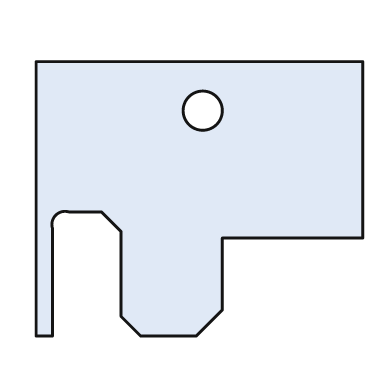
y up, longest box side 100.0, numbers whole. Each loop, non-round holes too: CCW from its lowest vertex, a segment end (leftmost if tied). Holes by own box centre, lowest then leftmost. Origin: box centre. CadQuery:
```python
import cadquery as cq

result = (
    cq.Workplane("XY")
    .moveTo(-50.0, -42.0)
    .lineTo(-45.0, -42.0)
    .lineTo(-45.0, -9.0)
    .threePointArc((-44.0, -5.0), (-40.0, -4.0))
    .lineTo(-30.0, -4.0)
    .lineTo(-24.0, -10.0)
    .lineTo(-24.0, -36.0)
    .lineTo(-18.0, -42.0)
    .lineTo(-1.0, -42.0)
    .lineTo(7.0, -34.0)
    .lineTo(7.0, -12.0)
    .lineTo(50.0, -12.0)
    .lineTo(50.0, 42.0)
    .lineTo(-50.0, 42.0)
    .close()
    .moveTo(1.0, 27.0)
    .circle(6.0)
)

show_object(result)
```